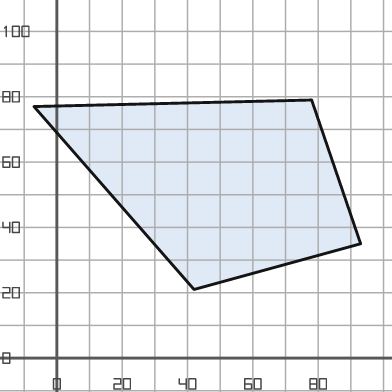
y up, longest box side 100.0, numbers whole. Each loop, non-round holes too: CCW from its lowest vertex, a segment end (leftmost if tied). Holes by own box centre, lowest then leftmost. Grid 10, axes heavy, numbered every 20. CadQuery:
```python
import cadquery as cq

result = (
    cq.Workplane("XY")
    .moveTo(42.0, 21.0)
    .lineTo(93.0, 35.0)
    .lineTo(78.0, 79.0)
    .lineTo(-7.0, 77.0)
    .close()
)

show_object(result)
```